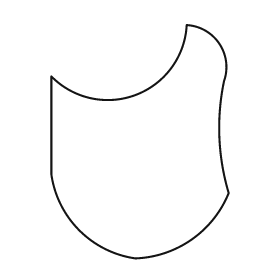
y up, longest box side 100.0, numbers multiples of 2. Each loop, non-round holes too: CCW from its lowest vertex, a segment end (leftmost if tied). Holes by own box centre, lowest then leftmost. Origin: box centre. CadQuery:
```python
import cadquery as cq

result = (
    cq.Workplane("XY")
    .moveTo(-2.0, -50.0)
    .threePointArc((22.0, -42.0), (38.0, -22.0))
    .threePointArc((34.0, 2.0), (36.0, 26.0))
    .threePointArc((34.0, 42.0), (20.0, 50.0))
    .threePointArc((-2.0, 20.0), (-38.0, 28.0))
    .lineTo(-38.0, -14.0)
    .threePointArc((-26.0, -38.0), (-2.0, -50.0))
    .close()
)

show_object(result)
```